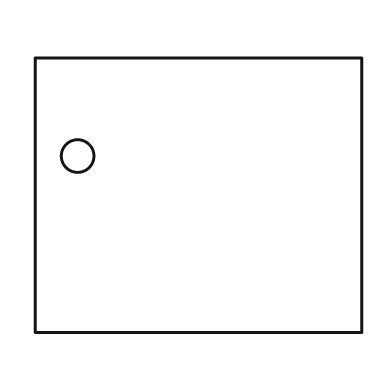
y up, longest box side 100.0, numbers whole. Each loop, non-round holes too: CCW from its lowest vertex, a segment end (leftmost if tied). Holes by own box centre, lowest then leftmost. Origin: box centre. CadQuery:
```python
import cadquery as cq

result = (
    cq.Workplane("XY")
    .moveTo(-50.0, -42.0)
    .lineTo(50.0, -42.0)
    .lineTo(50.0, 42.0)
    .lineTo(-50.0, 42.0)
    .close()
    .moveTo(-37.0, 12.0)
    .circle(5.0)
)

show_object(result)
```